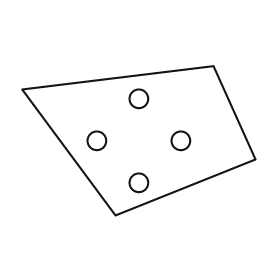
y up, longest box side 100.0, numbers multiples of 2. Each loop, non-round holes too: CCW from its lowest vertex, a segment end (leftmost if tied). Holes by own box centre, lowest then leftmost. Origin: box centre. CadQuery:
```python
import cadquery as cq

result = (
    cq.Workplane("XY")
    .moveTo(-10.0, -32.0)
    .lineTo(50.0, -8.0)
    .lineTo(32.0, 32.0)
    .lineTo(-50.0, 22.0)
    .close()
    .moveTo(0.0, -18.0)
    .circle(4.0)
    .moveTo(-18.0, 0.0)
    .circle(4.0)
    .moveTo(18.0, 0.0)
    .circle(4.0)
    .moveTo(0.0, 18.0)
    .circle(4.0)
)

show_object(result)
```